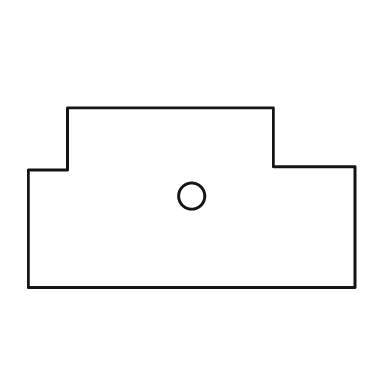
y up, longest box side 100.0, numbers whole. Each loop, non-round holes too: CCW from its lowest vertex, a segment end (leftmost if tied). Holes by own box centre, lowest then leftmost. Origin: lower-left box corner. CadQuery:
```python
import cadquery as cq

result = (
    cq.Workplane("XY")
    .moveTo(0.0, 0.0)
    .lineTo(100.0, 0.0)
    .lineTo(100.0, 37.0)
    .lineTo(75.0, 37.0)
    .lineTo(75.0, 55.0)
    .lineTo(12.0, 55.0)
    .lineTo(12.0, 36.0)
    .lineTo(0.0, 36.0)
    .close()
    .moveTo(50.0, 28.0)
    .circle(4.0)
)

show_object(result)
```